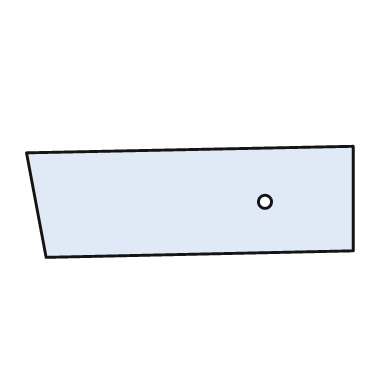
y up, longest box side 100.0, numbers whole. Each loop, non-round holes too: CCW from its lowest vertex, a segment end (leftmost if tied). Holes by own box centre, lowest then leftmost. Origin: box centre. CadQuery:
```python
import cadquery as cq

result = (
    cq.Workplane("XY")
    .moveTo(-44.0, -17.0)
    .lineTo(50.0, -15.0)
    .lineTo(50.0, 17.0)
    .lineTo(-50.0, 15.0)
    .close()
    .moveTo(23.0, 0.0)
    .circle(2.0)
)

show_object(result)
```